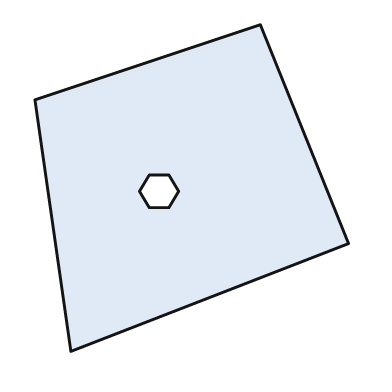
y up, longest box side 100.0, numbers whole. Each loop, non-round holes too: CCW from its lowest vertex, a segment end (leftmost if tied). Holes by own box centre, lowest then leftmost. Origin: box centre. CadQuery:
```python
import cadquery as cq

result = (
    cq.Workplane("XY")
    .moveTo(-37.0, -50.0)
    .lineTo(48.0, -17.0)
    .lineTo(21.0, 50.0)
    .lineTo(-48.0, 27.0)
    .close()
    .moveTo(-13.0, -6.0)
    .lineTo(-7.0, -6.0)
    .lineTo(-4.0, -1.0)
    .lineTo(-7.0, 4.0)
    .lineTo(-13.0, 4.0)
    .lineTo(-16.0, -1.0)
    .close()
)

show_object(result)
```